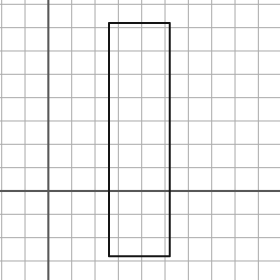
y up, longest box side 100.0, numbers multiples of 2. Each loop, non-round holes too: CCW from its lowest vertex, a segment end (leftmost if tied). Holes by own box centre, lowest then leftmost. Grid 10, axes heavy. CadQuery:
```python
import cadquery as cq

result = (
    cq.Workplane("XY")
    .moveTo(26.0, -28.0)
    .lineTo(52.0, -28.0)
    .lineTo(52.0, 72.0)
    .lineTo(26.0, 72.0)
    .close()
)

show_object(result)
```